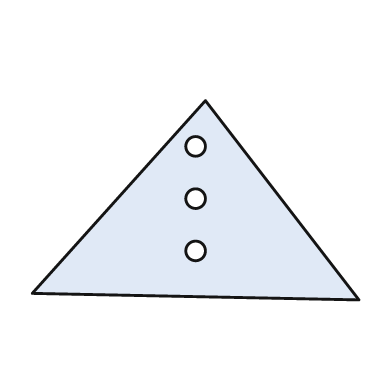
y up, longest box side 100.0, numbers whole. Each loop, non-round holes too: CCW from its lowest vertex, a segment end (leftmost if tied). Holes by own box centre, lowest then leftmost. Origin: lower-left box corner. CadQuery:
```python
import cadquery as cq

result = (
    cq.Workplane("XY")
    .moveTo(100.0, 0.0)
    .lineTo(53.0, 61.0)
    .lineTo(0.0, 2.0)
    .close()
    .moveTo(50.0, 15.0)
    .circle(3.0)
    .moveTo(50.0, 31.0)
    .circle(3.0)
    .moveTo(50.0, 47.0)
    .circle(3.0)
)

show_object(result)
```